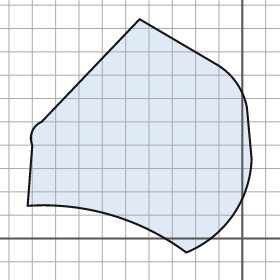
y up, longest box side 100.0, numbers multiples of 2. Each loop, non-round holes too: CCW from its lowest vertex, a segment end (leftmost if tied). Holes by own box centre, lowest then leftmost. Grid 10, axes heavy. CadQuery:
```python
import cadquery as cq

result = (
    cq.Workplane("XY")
    .moveTo(-24.0, -6.0)
    .threePointArc((-4.0, 10.0), (4.0, 34.0))
    .lineTo(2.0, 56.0)
    .threePointArc((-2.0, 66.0), (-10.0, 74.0))
    .lineTo(-44.0, 94.0)
    .lineTo(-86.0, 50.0)
    .threePointArc((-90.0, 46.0), (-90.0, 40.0))
    .lineTo(-92.0, 14.0)
    .threePointArc((-56.0, 10.0), (-24.0, -6.0))
    .close()
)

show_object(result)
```